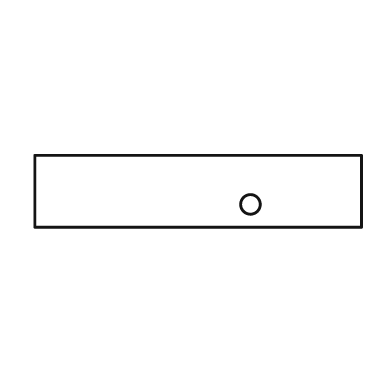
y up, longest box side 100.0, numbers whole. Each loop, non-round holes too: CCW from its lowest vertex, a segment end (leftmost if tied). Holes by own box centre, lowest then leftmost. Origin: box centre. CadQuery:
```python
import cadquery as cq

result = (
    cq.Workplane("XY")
    .moveTo(-50.0, -11.0)
    .lineTo(50.0, -11.0)
    .lineTo(50.0, 11.0)
    .lineTo(-50.0, 11.0)
    .close()
    .moveTo(16.0, -4.0)
    .circle(3.0)
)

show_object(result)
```